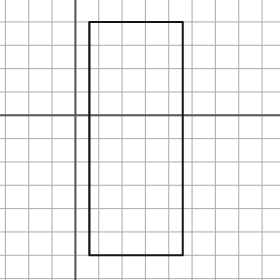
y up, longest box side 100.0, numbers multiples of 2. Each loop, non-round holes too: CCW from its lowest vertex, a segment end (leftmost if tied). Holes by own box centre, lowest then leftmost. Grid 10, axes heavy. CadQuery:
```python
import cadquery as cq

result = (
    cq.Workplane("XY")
    .moveTo(6.0, -60.0)
    .lineTo(46.0, -60.0)
    .lineTo(46.0, 40.0)
    .lineTo(6.0, 40.0)
    .close()
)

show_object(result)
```